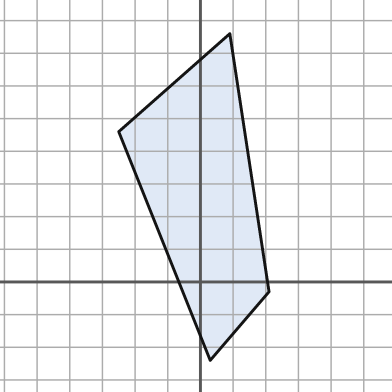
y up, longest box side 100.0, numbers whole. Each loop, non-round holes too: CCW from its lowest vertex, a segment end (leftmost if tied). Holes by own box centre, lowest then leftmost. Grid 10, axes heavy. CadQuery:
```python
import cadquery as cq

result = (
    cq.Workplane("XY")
    .moveTo(3.0, -24.0)
    .lineTo(21.0, -3.0)
    .lineTo(9.0, 76.0)
    .lineTo(-25.0, 46.0)
    .close()
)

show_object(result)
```